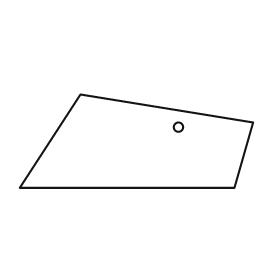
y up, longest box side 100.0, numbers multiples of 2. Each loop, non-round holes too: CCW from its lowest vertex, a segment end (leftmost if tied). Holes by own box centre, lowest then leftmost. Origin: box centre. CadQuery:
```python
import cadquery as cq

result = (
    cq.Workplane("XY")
    .moveTo(-50.0, -20.0)
    .lineTo(42.0, -20.0)
    .lineTo(50.0, 8.0)
    .lineTo(-24.0, 20.0)
    .close()
    .moveTo(18.0, 6.0)
    .circle(2.0)
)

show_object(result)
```